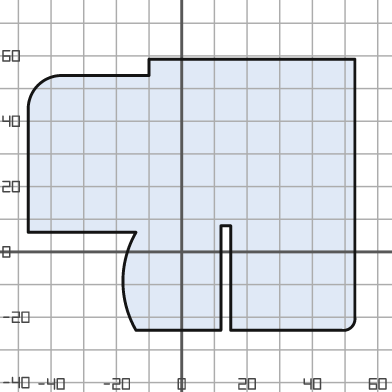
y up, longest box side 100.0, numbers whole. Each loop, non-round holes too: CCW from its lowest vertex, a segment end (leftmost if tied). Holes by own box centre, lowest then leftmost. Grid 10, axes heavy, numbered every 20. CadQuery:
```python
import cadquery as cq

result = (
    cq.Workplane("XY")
    .moveTo(-14.0, -24.0)
    .lineTo(12.0, -24.0)
    .lineTo(12.0, 8.0)
    .lineTo(15.0, 8.0)
    .lineTo(15.0, -24.0)
    .lineTo(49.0, -24.0)
    .threePointArc((52.0, -23.0), (53.0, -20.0))
    .lineTo(53.0, 59.0)
    .lineTo(-10.0, 59.0)
    .lineTo(-10.0, 54.0)
    .lineTo(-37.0, 54.0)
    .threePointArc((-44.0, 51.0), (-47.0, 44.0))
    .lineTo(-47.0, 6.0)
    .lineTo(-14.0, 6.0)
    .threePointArc((-18.0, -9.0), (-14.0, -24.0))
    .close()
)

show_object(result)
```